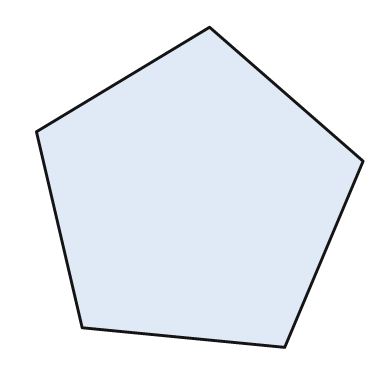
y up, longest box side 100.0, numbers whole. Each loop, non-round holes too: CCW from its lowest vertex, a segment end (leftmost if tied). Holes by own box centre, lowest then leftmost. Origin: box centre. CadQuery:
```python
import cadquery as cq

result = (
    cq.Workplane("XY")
    .moveTo(26.0, -49.0)
    .lineTo(50.0, 8.0)
    .lineTo(3.0, 49.0)
    .lineTo(-50.0, 17.0)
    .lineTo(-36.0, -43.0)
    .close()
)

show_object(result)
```